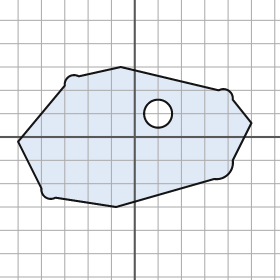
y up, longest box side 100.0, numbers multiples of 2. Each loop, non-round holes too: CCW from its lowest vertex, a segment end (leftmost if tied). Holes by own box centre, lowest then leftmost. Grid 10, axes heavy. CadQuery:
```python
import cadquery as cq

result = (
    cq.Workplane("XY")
    .moveTo(-8.0, -30.0)
    .lineTo(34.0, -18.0)
    .threePointArc((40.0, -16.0), (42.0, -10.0))
    .lineTo(50.0, 6.0)
    .lineTo(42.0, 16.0)
    .threePointArc((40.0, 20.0), (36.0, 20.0))
    .lineTo(-6.0, 30.0)
    .lineTo(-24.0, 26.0)
    .threePointArc((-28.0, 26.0), (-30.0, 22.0))
    .lineTo(-50.0, -2.0)
    .lineTo(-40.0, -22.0)
    .threePointArc((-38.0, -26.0), (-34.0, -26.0))
    .close()
    .moveTo(10.0, 10.0)
    .circle(6.0)
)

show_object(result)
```